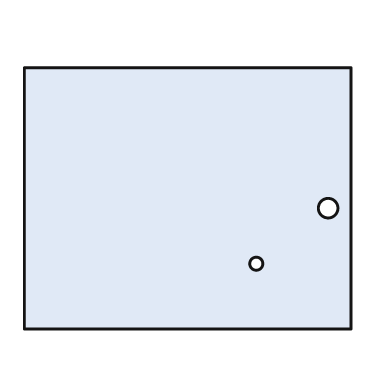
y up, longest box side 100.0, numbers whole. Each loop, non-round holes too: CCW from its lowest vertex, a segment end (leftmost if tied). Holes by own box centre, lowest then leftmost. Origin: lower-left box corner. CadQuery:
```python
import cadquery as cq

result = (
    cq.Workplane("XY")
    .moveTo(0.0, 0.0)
    .lineTo(100.0, 0.0)
    .lineTo(100.0, 80.0)
    .lineTo(0.0, 80.0)
    .close()
    .moveTo(71.0, 20.0)
    .circle(2.0)
    .moveTo(93.0, 37.0)
    .circle(3.0)
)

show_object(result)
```